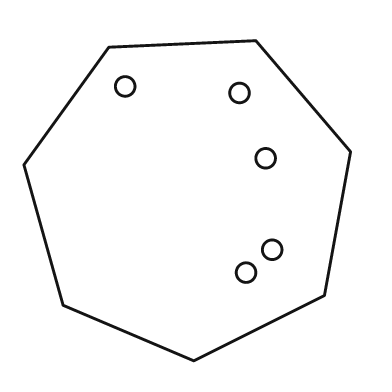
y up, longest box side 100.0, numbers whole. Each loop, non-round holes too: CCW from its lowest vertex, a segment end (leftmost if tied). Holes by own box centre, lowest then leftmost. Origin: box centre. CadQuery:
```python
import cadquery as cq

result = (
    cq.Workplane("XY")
    .moveTo(2.0, -49.0)
    .lineTo(42.0, -29.0)
    .lineTo(50.0, 15.0)
    .lineTo(21.0, 49.0)
    .lineTo(-24.0, 47.0)
    .lineTo(-50.0, 11.0)
    .lineTo(-38.0, -32.0)
    .close()
    .moveTo(18.0, -22.0)
    .circle(3.0)
    .moveTo(26.0, -15.0)
    .circle(3.0)
    .moveTo(24.0, 13.0)
    .circle(3.0)
    .moveTo(16.0, 33.0)
    .circle(3.0)
    .moveTo(-19.0, 35.0)
    .circle(3.0)
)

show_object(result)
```